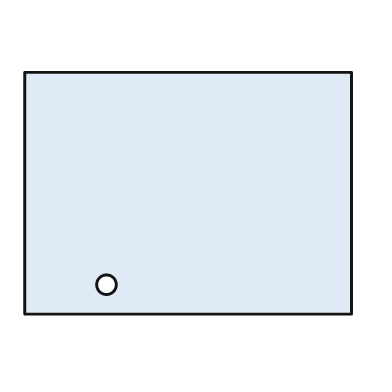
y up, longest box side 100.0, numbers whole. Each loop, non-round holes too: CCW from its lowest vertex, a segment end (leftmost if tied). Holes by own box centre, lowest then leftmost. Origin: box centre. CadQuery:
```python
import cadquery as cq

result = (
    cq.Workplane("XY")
    .moveTo(-50.0, -37.0)
    .lineTo(50.0, -37.0)
    .lineTo(50.0, 37.0)
    .lineTo(-50.0, 37.0)
    .close()
    .moveTo(-25.0, -28.0)
    .circle(3.0)
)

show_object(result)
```